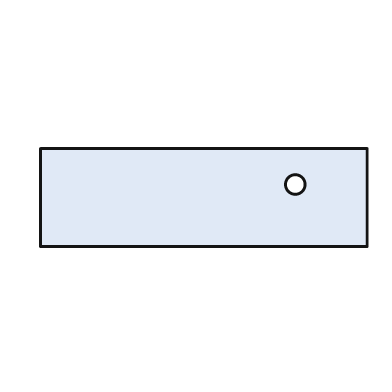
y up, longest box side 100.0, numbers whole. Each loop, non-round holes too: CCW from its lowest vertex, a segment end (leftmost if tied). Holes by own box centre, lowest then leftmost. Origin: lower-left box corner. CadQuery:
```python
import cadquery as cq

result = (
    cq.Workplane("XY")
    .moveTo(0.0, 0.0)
    .lineTo(100.0, 0.0)
    .lineTo(100.0, 30.0)
    .lineTo(0.0, 30.0)
    .close()
    .moveTo(78.0, 19.0)
    .circle(3.0)
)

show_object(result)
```